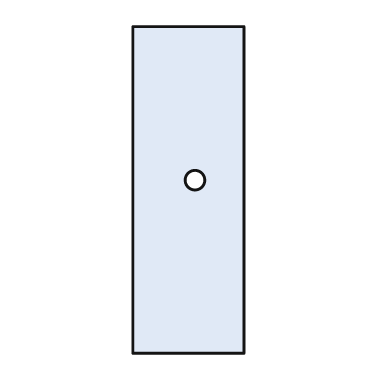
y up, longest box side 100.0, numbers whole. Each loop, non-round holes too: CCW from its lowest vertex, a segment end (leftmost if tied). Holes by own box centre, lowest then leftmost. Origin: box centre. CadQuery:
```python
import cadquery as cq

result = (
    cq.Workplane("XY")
    .moveTo(-17.0, -50.0)
    .lineTo(17.0, -50.0)
    .lineTo(17.0, 50.0)
    .lineTo(-17.0, 50.0)
    .close()
    .moveTo(2.0, 3.0)
    .circle(3.0)
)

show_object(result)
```